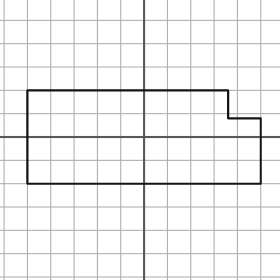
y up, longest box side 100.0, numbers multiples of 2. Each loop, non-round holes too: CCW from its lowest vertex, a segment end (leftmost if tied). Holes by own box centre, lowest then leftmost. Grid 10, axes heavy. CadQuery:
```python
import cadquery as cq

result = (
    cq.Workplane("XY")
    .moveTo(-50.0, -20.0)
    .lineTo(50.0, -20.0)
    .lineTo(50.0, 8.0)
    .lineTo(36.0, 8.0)
    .lineTo(36.0, 20.0)
    .lineTo(-50.0, 20.0)
    .close()
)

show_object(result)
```